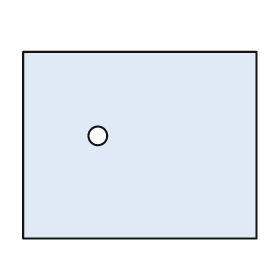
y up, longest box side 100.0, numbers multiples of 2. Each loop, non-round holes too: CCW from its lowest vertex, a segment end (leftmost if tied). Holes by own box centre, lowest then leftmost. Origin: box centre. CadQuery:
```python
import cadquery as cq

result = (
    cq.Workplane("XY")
    .moveTo(-50.0, -40.0)
    .lineTo(50.0, -40.0)
    .lineTo(50.0, 40.0)
    .lineTo(-50.0, 40.0)
    .close()
    .moveTo(-18.0, 4.0)
    .circle(4.0)
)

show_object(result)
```